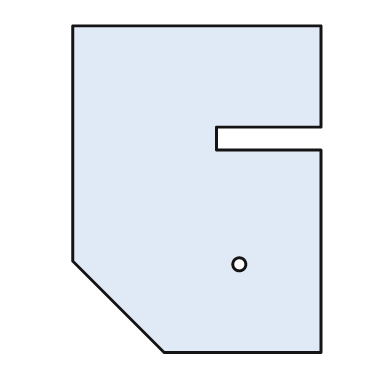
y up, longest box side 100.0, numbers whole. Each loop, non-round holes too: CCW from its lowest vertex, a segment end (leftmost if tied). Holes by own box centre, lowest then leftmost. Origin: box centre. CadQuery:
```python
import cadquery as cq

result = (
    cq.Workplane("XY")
    .moveTo(-10.0, -50.0)
    .lineTo(38.0, -50.0)
    .lineTo(38.0, 12.0)
    .lineTo(6.0, 12.0)
    .lineTo(6.0, 19.0)
    .lineTo(38.0, 19.0)
    .lineTo(38.0, 50.0)
    .lineTo(-38.0, 50.0)
    .lineTo(-38.0, -22.0)
    .close()
    .moveTo(13.0, -23.0)
    .circle(2.0)
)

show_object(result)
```